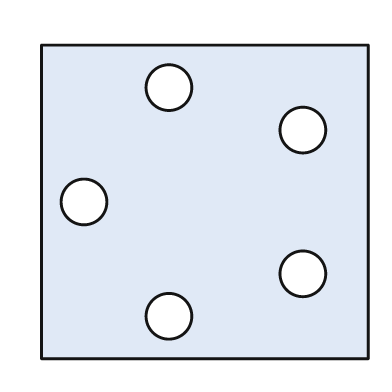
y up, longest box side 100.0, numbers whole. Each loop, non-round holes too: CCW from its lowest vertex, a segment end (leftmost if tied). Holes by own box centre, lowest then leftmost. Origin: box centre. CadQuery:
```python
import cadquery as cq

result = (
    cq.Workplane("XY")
    .moveTo(-50.0, -48.0)
    .lineTo(50.0, -48.0)
    .lineTo(50.0, 48.0)
    .lineTo(-50.0, 48.0)
    .close()
    .moveTo(-11.0, -35.0)
    .circle(7.0)
    .moveTo(30.0, -22.0)
    .circle(7.0)
    .moveTo(-37.0, 0.0)
    .circle(7.0)
    .moveTo(30.0, 22.0)
    .circle(7.0)
    .moveTo(-11.0, 35.0)
    .circle(7.0)
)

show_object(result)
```